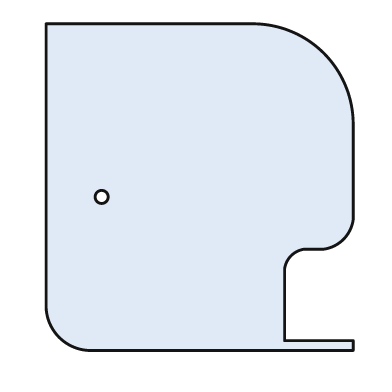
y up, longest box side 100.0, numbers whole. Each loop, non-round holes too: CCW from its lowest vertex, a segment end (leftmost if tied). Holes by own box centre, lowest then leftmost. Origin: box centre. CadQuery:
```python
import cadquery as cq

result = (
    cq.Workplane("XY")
    .moveTo(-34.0, -50.0)
    .lineTo(47.0, -50.0)
    .lineTo(47.0, -47.0)
    .lineTo(26.0, -47.0)
    .lineTo(26.0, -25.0)
    .threePointArc((28.0, -21.0), (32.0, -19.0))
    .lineTo(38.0, -19.0)
    .threePointArc((44.0, -16.0), (47.0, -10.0))
    .lineTo(47.0, 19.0)
    .threePointArc((38.0, 41.0), (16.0, 50.0))
    .lineTo(-47.0, 50.0)
    .lineTo(-47.0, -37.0)
    .threePointArc((-43.0, -46.0), (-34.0, -50.0))
    .close()
    .moveTo(-30.0, -3.0)
    .circle(2.0)
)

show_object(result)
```